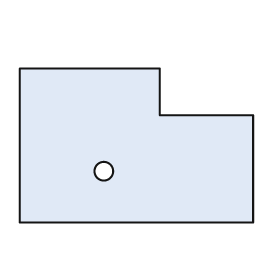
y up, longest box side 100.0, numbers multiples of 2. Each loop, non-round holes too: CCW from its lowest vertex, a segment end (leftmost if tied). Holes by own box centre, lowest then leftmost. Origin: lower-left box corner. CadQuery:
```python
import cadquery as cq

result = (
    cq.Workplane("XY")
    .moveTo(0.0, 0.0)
    .lineTo(100.0, 0.0)
    .lineTo(100.0, 46.0)
    .lineTo(60.0, 46.0)
    .lineTo(60.0, 66.0)
    .lineTo(0.0, 66.0)
    .close()
    .moveTo(36.0, 22.0)
    .circle(4.0)
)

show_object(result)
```